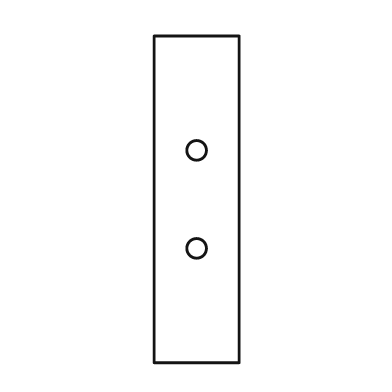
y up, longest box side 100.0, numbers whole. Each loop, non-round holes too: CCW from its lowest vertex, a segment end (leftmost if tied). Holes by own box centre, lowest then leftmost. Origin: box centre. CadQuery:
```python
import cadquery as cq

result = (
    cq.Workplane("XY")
    .moveTo(-13.0, -50.0)
    .lineTo(13.0, -50.0)
    .lineTo(13.0, 50.0)
    .lineTo(-13.0, 50.0)
    .close()
    .moveTo(0.0, -15.0)
    .circle(3.0)
    .moveTo(0.0, 15.0)
    .circle(3.0)
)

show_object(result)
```